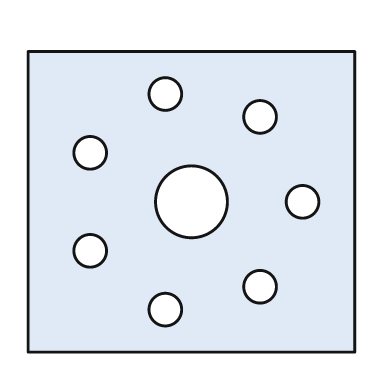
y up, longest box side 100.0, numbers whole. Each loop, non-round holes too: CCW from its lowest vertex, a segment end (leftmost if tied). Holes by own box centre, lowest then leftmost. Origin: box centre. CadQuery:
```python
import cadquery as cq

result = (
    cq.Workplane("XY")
    .moveTo(-50.0, -46.0)
    .lineTo(50.0, -46.0)
    .lineTo(50.0, 46.0)
    .lineTo(-50.0, 46.0)
    .close()
    .moveTo(-8.0, -33.0)
    .circle(5.0)
    .moveTo(21.0, -26.0)
    .circle(5.0)
    .moveTo(-31.0, -15.0)
    .circle(5.0)
    .moveTo(0.0, 0.0)
    .circle(11.0)
    .moveTo(34.0, 0.0)
    .circle(5.0)
    .moveTo(-31.0, 15.0)
    .circle(5.0)
    .moveTo(21.0, 26.0)
    .circle(5.0)
    .moveTo(-8.0, 33.0)
    .circle(5.0)
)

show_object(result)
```